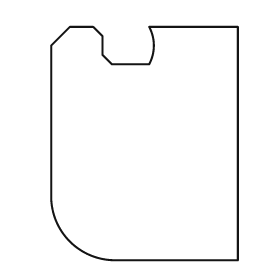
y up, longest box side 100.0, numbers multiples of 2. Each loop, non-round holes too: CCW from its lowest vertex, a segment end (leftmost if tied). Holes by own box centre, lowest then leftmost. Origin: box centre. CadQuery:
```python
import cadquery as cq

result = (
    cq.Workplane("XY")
    .moveTo(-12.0, -50.0)
    .lineTo(40.0, -50.0)
    .lineTo(40.0, 50.0)
    .lineTo(2.0, 50.0)
    .threePointArc((4.0, 42.0), (2.0, 34.0))
    .lineTo(-14.0, 34.0)
    .lineTo(-18.0, 38.0)
    .lineTo(-18.0, 46.0)
    .lineTo(-22.0, 50.0)
    .lineTo(-32.0, 50.0)
    .lineTo(-40.0, 42.0)
    .lineTo(-40.0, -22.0)
    .threePointArc((-32.0, -42.0), (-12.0, -50.0))
    .close()
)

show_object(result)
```